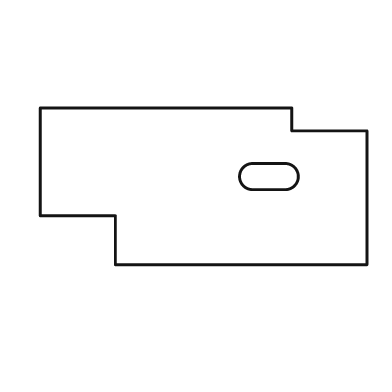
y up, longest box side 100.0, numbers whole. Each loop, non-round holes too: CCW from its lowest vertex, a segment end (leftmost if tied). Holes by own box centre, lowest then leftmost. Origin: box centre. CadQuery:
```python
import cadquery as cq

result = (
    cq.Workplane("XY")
    .moveTo(-27.0, -24.0)
    .lineTo(50.0, -24.0)
    .lineTo(50.0, 17.0)
    .lineTo(27.0, 17.0)
    .lineTo(27.0, 24.0)
    .lineTo(-50.0, 24.0)
    .lineTo(-50.0, -9.0)
    .lineTo(-27.0, -9.0)
    .close()
    .moveTo(15.0, -1.0)
    .lineTo(25.0, -1.0)
    .threePointArc((29.0, 3.0), (25.0, 7.0))
    .lineTo(15.0, 7.0)
    .threePointArc((11.0, 3.0), (15.0, -1.0))
    .close()
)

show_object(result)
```